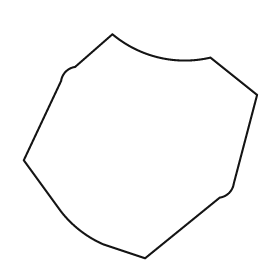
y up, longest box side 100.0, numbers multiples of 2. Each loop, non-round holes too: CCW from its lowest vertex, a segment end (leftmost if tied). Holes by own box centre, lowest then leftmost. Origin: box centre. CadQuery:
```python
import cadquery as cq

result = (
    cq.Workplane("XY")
    .moveTo(2.0, -48.0)
    .lineTo(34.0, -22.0)
    .threePointArc((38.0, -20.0), (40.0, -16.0))
    .lineTo(50.0, 22.0)
    .lineTo(30.0, 38.0)
    .threePointArc((8.0, 38.0), (-12.0, 48.0))
    .lineTo(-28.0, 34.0)
    .threePointArc((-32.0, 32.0), (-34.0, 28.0))
    .lineTo(-50.0, -6.0)
    .lineTo(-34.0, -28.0)
    .threePointArc((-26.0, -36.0), (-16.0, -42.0))
    .close()
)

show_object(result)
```